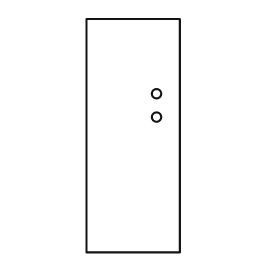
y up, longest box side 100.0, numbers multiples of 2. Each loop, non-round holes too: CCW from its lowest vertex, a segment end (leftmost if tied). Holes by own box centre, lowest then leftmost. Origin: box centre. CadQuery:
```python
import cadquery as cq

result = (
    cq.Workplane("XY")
    .moveTo(-20.0, -50.0)
    .lineTo(20.0, -50.0)
    .lineTo(20.0, 50.0)
    .lineTo(-20.0, 50.0)
    .close()
    .moveTo(10.0, 8.0)
    .circle(2.0)
    .moveTo(10.0, 18.0)
    .circle(2.0)
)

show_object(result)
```